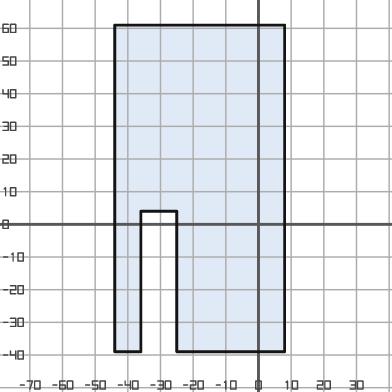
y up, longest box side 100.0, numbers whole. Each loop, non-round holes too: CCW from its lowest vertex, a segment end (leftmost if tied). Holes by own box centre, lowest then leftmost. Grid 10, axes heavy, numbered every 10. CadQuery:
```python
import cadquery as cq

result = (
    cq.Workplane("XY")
    .moveTo(-44.0, -39.0)
    .lineTo(-36.0, -39.0)
    .lineTo(-36.0, 4.0)
    .lineTo(-25.0, 4.0)
    .lineTo(-25.0, -39.0)
    .lineTo(8.0, -39.0)
    .lineTo(8.0, 61.0)
    .lineTo(-44.0, 61.0)
    .close()
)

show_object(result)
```